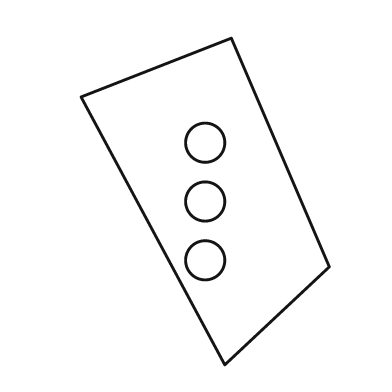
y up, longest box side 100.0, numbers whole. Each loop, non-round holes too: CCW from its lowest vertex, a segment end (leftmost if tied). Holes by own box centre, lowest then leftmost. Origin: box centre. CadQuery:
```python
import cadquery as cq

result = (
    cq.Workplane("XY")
    .moveTo(6.0, -50.0)
    .lineTo(38.0, -20.0)
    .lineTo(8.0, 50.0)
    .lineTo(-38.0, 32.0)
    .close()
    .moveTo(0.0, -18.0)
    .circle(6.0)
    .moveTo(0.0, 0.0)
    .circle(6.0)
    .moveTo(0.0, 18.0)
    .circle(6.0)
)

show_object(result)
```